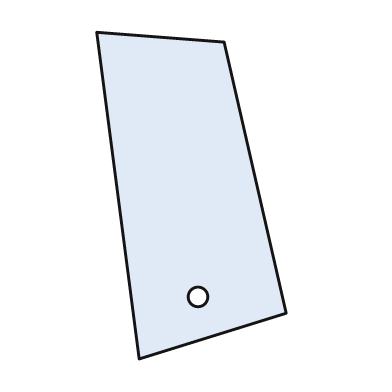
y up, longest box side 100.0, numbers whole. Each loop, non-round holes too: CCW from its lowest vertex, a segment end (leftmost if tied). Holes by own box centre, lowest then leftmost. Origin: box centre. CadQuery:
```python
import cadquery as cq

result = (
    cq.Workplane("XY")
    .moveTo(-16.0, -50.0)
    .lineTo(29.0, -36.0)
    .lineTo(10.0, 47.0)
    .lineTo(-29.0, 50.0)
    .close()
    .moveTo(2.0, -31.0)
    .circle(3.0)
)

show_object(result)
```